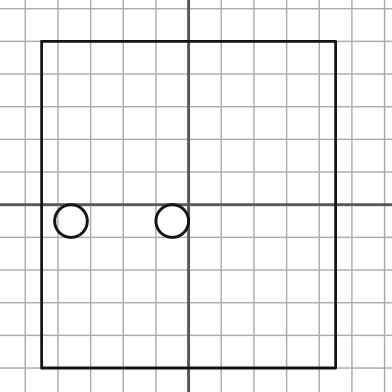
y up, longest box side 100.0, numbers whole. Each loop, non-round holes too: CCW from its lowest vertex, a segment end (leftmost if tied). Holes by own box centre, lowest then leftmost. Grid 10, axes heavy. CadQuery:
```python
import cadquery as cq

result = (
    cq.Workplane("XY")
    .moveTo(-45.0, -50.0)
    .lineTo(45.0, -50.0)
    .lineTo(45.0, 50.0)
    .lineTo(-45.0, 50.0)
    .close()
    .moveTo(-36.0, -5.0)
    .circle(5.0)
    .moveTo(-5.0, -5.0)
    .circle(5.0)
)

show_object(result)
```